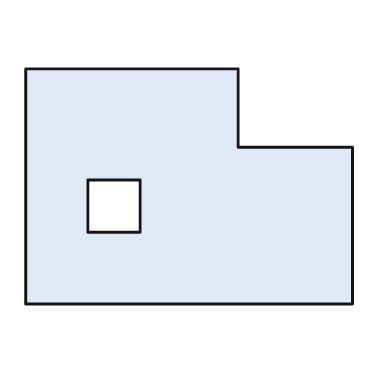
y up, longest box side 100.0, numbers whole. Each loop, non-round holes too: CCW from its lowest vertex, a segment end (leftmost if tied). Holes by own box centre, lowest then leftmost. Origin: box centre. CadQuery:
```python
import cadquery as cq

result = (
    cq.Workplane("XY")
    .moveTo(-50.0, -36.0)
    .lineTo(50.0, -36.0)
    .lineTo(50.0, 12.0)
    .lineTo(15.0, 12.0)
    .lineTo(15.0, 36.0)
    .lineTo(-50.0, 36.0)
    .close()
    .moveTo(-31.0, -14.0)
    .lineTo(-15.0, -14.0)
    .lineTo(-15.0, 2.0)
    .lineTo(-31.0, 2.0)
    .close()
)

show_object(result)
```